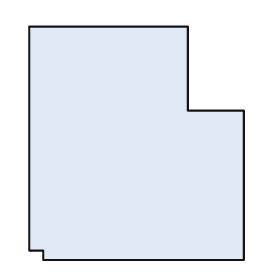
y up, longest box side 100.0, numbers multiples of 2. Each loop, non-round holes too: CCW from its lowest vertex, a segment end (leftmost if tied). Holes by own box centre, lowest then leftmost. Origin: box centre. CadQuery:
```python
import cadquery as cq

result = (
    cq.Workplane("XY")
    .moveTo(-40.0, -50.0)
    .lineTo(46.0, -50.0)
    .lineTo(46.0, 14.0)
    .lineTo(22.0, 14.0)
    .lineTo(22.0, 50.0)
    .lineTo(-46.0, 50.0)
    .lineTo(-46.0, -46.0)
    .lineTo(-40.0, -46.0)
    .close()
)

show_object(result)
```